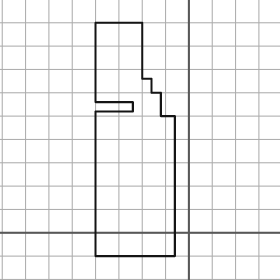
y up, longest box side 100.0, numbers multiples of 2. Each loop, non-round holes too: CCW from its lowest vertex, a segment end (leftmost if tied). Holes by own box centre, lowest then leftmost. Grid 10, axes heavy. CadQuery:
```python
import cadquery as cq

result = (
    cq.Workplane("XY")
    .moveTo(-40.0, -10.0)
    .lineTo(-6.0, -10.0)
    .lineTo(-6.0, 50.0)
    .lineTo(-12.0, 50.0)
    .lineTo(-12.0, 60.0)
    .lineTo(-16.0, 60.0)
    .lineTo(-16.0, 66.0)
    .lineTo(-20.0, 66.0)
    .lineTo(-20.0, 90.0)
    .lineTo(-40.0, 90.0)
    .lineTo(-40.0, 56.0)
    .lineTo(-24.0, 56.0)
    .lineTo(-24.0, 52.0)
    .lineTo(-40.0, 52.0)
    .close()
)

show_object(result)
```